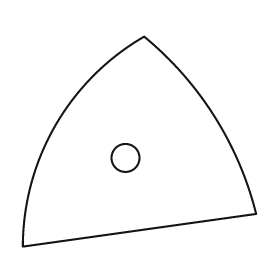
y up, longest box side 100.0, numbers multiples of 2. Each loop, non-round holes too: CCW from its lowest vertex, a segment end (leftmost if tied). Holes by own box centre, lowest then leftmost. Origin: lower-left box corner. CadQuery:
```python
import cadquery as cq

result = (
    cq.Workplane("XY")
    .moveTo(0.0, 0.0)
    .lineTo(100.0, 14.0)
    .threePointArc((82.0, 56.0), (52.0, 90.0))
    .threePointArc((14.0, 52.0), (0.0, 0.0))
    .close()
    .moveTo(44.0, 38.0)
    .circle(6.0)
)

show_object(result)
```